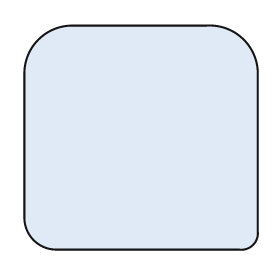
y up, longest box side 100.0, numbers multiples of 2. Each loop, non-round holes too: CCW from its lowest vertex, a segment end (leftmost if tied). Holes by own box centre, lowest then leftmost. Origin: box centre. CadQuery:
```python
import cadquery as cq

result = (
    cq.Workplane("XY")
    .moveTo(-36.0, -48.0)
    .lineTo(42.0, -48.0)
    .threePointArc((48.0, -46.0), (50.0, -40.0))
    .lineTo(50.0, 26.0)
    .threePointArc((44.0, 42.0), (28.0, 48.0))
    .lineTo(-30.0, 48.0)
    .threePointArc((-44.0, 42.0), (-50.0, 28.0))
    .lineTo(-50.0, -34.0)
    .threePointArc((-46.0, -44.0), (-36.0, -48.0))
    .close()
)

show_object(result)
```